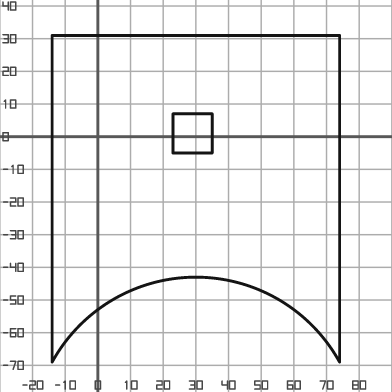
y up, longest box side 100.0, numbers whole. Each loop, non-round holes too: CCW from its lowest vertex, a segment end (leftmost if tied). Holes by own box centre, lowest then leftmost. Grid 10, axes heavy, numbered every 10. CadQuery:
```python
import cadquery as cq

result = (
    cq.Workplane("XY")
    .moveTo(-14.0, -69.0)
    .threePointArc((30.0, -43.0), (74.0, -69.0))
    .lineTo(74.0, 31.0)
    .lineTo(-14.0, 31.0)
    .close()
    .moveTo(23.0, -5.0)
    .lineTo(35.0, -5.0)
    .lineTo(35.0, 7.0)
    .lineTo(23.0, 7.0)
    .close()
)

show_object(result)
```